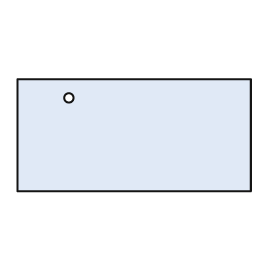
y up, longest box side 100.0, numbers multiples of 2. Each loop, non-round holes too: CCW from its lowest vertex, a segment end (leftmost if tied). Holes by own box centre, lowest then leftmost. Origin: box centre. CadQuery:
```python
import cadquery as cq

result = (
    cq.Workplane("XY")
    .moveTo(-50.0, -24.0)
    .lineTo(50.0, -24.0)
    .lineTo(50.0, 24.0)
    .lineTo(-50.0, 24.0)
    .close()
    .moveTo(-28.0, 16.0)
    .circle(2.0)
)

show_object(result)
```